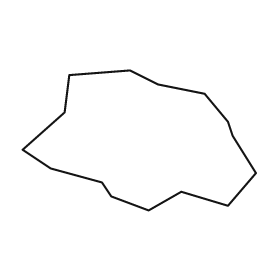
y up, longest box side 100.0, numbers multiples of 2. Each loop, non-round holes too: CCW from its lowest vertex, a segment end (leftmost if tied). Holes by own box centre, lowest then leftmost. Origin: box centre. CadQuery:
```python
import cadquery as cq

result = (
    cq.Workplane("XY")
    .moveTo(4.0, -30.0)
    .lineTo(18.0, -22.0)
    .lineTo(38.0, -28.0)
    .lineTo(50.0, -14.0)
    .lineTo(40.0, 2.0)
    .lineTo(38.0, 8.0)
    .lineTo(28.0, 20.0)
    .lineTo(8.0, 24.0)
    .lineTo(-4.0, 30.0)
    .lineTo(-30.0, 28.0)
    .lineTo(-32.0, 12.0)
    .lineTo(-50.0, -4.0)
    .lineTo(-38.0, -12.0)
    .lineTo(-16.0, -18.0)
    .lineTo(-12.0, -24.0)
    .close()
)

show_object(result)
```